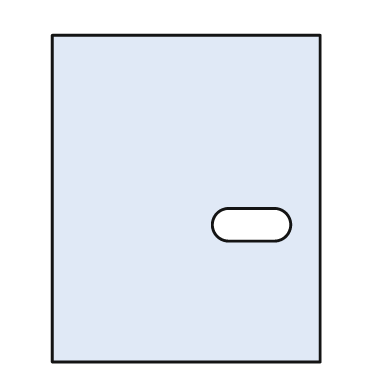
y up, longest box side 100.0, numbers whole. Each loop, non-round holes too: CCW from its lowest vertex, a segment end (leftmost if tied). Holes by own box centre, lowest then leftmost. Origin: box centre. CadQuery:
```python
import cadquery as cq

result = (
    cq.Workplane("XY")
    .moveTo(-41.0, -50.0)
    .lineTo(41.0, -50.0)
    .lineTo(41.0, 50.0)
    .lineTo(-41.0, 50.0)
    .close()
    .moveTo(13.0, -13.0)
    .lineTo(27.0, -13.0)
    .threePointArc((32.0, -8.0), (27.0, -3.0))
    .lineTo(13.0, -3.0)
    .threePointArc((8.0, -8.0), (13.0, -13.0))
    .close()
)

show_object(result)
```